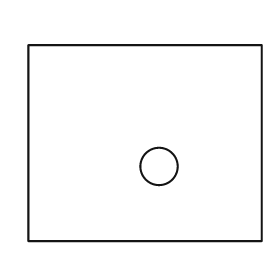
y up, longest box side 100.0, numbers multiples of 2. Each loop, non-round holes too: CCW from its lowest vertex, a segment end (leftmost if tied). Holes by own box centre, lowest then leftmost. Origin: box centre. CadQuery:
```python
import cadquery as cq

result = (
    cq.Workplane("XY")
    .moveTo(-50.0, -42.0)
    .lineTo(50.0, -42.0)
    .lineTo(50.0, 42.0)
    .lineTo(-50.0, 42.0)
    .close()
    .moveTo(6.0, -10.0)
    .circle(8.0)
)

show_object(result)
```